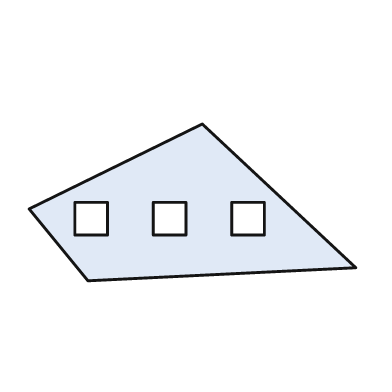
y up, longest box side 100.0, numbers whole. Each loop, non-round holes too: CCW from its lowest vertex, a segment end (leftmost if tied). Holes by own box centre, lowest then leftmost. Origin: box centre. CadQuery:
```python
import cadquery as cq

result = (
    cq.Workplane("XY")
    .moveTo(-32.0, -24.0)
    .lineTo(50.0, -20.0)
    .lineTo(3.0, 24.0)
    .lineTo(-50.0, -2.0)
    .close()
    .moveTo(-36.0, -10.0)
    .lineTo(-26.0, -10.0)
    .lineTo(-26.0, 0.0)
    .lineTo(-36.0, 0.0)
    .close()
    .moveTo(-12.0, -10.0)
    .lineTo(-2.0, -10.0)
    .lineTo(-2.0, 0.0)
    .lineTo(-12.0, 0.0)
    .close()
    .moveTo(12.0, -10.0)
    .lineTo(22.0, -10.0)
    .lineTo(22.0, 0.0)
    .lineTo(12.0, 0.0)
    .close()
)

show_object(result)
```